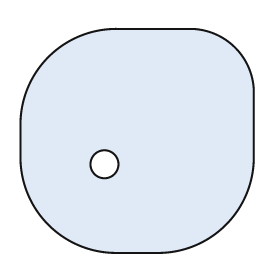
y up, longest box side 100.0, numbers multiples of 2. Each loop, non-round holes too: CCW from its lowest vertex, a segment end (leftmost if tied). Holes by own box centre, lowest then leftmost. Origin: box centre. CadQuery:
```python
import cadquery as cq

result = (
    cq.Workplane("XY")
    .moveTo(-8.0, -48.0)
    .lineTo(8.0, -48.0)
    .threePointArc((38.0, -36.0), (50.0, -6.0))
    .lineTo(50.0, 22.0)
    .threePointArc((42.0, 40.0), (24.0, 48.0))
    .lineTo(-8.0, 48.0)
    .threePointArc((-38.0, 36.0), (-50.0, 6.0))
    .lineTo(-50.0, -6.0)
    .threePointArc((-38.0, -36.0), (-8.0, -48.0))
    .close()
    .moveTo(-14.0, -10.0)
    .circle(6.0)
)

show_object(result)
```